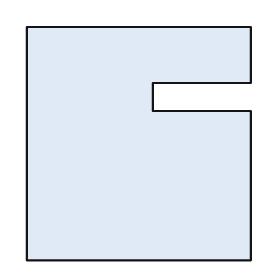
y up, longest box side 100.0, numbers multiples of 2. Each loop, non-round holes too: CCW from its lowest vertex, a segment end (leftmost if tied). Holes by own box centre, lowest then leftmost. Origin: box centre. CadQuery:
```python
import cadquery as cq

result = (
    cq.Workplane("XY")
    .moveTo(-48.0, -50.0)
    .lineTo(48.0, -50.0)
    .lineTo(48.0, 14.0)
    .lineTo(6.0, 14.0)
    .lineTo(6.0, 26.0)
    .lineTo(48.0, 26.0)
    .lineTo(48.0, 50.0)
    .lineTo(-48.0, 50.0)
    .close()
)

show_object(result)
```